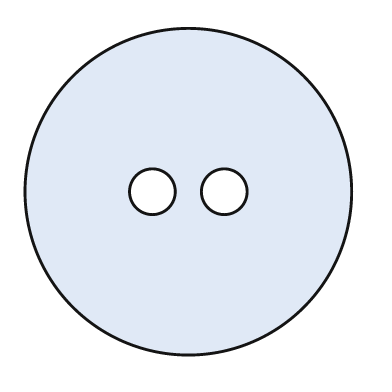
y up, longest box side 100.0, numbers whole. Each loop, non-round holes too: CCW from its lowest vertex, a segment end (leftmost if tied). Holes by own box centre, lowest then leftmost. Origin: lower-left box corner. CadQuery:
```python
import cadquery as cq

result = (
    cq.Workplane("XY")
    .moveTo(50.0, 50.0)
    .circle(50.0)
    .moveTo(39.0, 50.0)
    .circle(7.0)
    .moveTo(61.0, 50.0)
    .circle(7.0)
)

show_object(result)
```